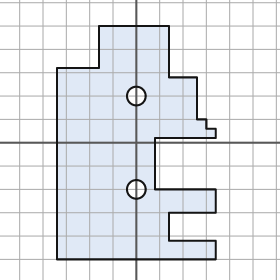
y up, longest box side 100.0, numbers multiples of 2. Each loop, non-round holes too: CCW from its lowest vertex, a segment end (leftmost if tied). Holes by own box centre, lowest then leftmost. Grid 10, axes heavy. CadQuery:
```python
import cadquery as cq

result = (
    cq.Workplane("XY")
    .moveTo(-34.0, -50.0)
    .lineTo(34.0, -50.0)
    .lineTo(34.0, -42.0)
    .lineTo(14.0, -42.0)
    .lineTo(14.0, -30.0)
    .lineTo(34.0, -30.0)
    .lineTo(34.0, -20.0)
    .lineTo(8.0, -20.0)
    .lineTo(8.0, 2.0)
    .lineTo(34.0, 2.0)
    .lineTo(34.0, 6.0)
    .lineTo(30.0, 6.0)
    .lineTo(30.0, 10.0)
    .lineTo(26.0, 10.0)
    .lineTo(26.0, 28.0)
    .lineTo(14.0, 28.0)
    .lineTo(14.0, 50.0)
    .lineTo(-16.0, 50.0)
    .lineTo(-16.0, 32.0)
    .lineTo(-34.0, 32.0)
    .close()
    .moveTo(0.0, -20.0)
    .circle(4.0)
    .moveTo(0.0, 20.0)
    .circle(4.0)
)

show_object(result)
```